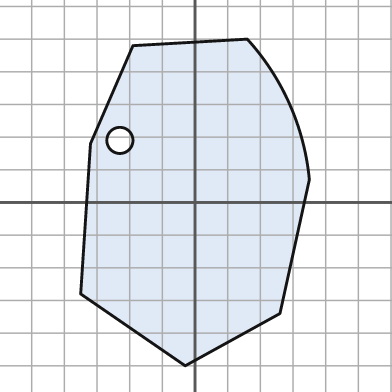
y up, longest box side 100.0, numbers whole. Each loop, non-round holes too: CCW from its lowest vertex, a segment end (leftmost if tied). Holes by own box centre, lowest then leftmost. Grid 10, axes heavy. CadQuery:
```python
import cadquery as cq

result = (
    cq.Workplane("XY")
    .moveTo(-3.0, -50.0)
    .lineTo(26.0, -34.0)
    .lineTo(35.0, 7.0)
    .threePointArc((29.0, 30.0), (16.0, 50.0))
    .lineTo(-19.0, 48.0)
    .lineTo(-32.0, 18.0)
    .lineTo(-35.0, -28.0)
    .close()
    .moveTo(-23.0, 19.0)
    .circle(4.0)
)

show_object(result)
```